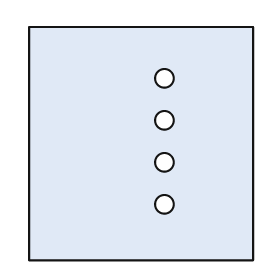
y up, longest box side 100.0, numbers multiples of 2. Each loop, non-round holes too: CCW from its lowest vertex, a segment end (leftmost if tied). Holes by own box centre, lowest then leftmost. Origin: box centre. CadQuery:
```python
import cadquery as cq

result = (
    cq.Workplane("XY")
    .moveTo(-48.0, -50.0)
    .lineTo(48.0, -50.0)
    .lineTo(48.0, 50.0)
    .lineTo(-48.0, 50.0)
    .close()
    .moveTo(10.0, -26.0)
    .circle(4.0)
    .moveTo(10.0, -8.0)
    .circle(4.0)
    .moveTo(10.0, 10.0)
    .circle(4.0)
    .moveTo(10.0, 28.0)
    .circle(4.0)
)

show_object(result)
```